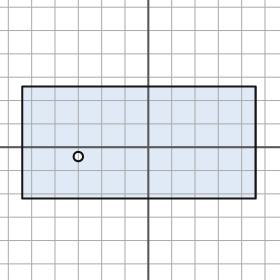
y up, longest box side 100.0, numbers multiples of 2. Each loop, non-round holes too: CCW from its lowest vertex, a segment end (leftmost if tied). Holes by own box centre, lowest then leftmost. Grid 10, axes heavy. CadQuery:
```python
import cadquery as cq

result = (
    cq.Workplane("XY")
    .moveTo(-54.0, -22.0)
    .lineTo(46.0, -22.0)
    .lineTo(46.0, 26.0)
    .lineTo(-54.0, 26.0)
    .close()
    .moveTo(-30.0, -4.0)
    .circle(2.0)
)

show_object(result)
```